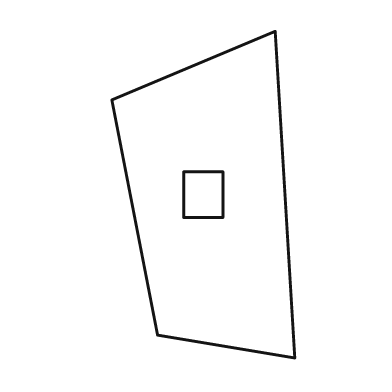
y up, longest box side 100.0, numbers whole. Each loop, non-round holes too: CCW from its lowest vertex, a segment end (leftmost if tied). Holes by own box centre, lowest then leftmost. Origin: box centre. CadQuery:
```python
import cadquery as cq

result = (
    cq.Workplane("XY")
    .moveTo(28.0, -50.0)
    .lineTo(22.0, 50.0)
    .lineTo(-28.0, 29.0)
    .lineTo(-14.0, -43.0)
    .close()
    .moveTo(-6.0, -7.0)
    .lineTo(6.0, -7.0)
    .lineTo(6.0, 7.0)
    .lineTo(-6.0, 7.0)
    .close()
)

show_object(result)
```